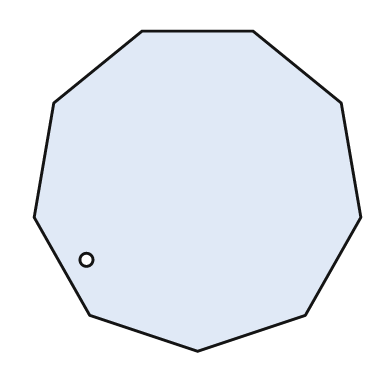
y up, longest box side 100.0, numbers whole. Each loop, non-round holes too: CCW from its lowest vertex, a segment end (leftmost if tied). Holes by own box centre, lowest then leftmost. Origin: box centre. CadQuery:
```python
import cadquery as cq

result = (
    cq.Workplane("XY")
    .moveTo(0.0, -49.0)
    .lineTo(33.0, -38.0)
    .lineTo(50.0, -8.0)
    .lineTo(44.0, 27.0)
    .lineTo(17.0, 49.0)
    .lineTo(-17.0, 49.0)
    .lineTo(-44.0, 27.0)
    .lineTo(-50.0, -8.0)
    .lineTo(-33.0, -38.0)
    .close()
    .moveTo(-34.0, -21.0)
    .circle(2.0)
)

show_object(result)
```